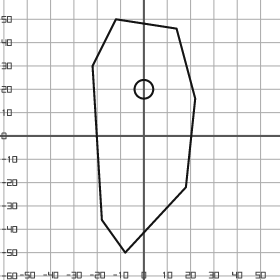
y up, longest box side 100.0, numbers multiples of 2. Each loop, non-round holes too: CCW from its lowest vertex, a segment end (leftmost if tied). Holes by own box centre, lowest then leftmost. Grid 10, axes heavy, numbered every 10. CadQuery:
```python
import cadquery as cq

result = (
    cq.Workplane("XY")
    .moveTo(-8.0, -50.0)
    .lineTo(18.0, -22.0)
    .lineTo(22.0, 16.0)
    .lineTo(14.0, 46.0)
    .lineTo(-12.0, 50.0)
    .lineTo(-22.0, 30.0)
    .lineTo(-18.0, -36.0)
    .close()
    .moveTo(0.0, 20.0)
    .circle(4.0)
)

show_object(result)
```